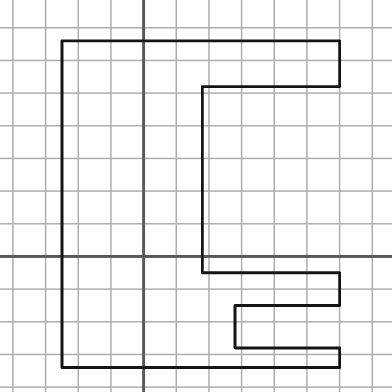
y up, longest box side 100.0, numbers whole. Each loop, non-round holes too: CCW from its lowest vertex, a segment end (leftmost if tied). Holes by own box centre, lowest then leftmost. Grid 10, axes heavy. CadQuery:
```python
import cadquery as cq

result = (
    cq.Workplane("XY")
    .moveTo(-25.0, -34.0)
    .lineTo(60.0, -34.0)
    .lineTo(60.0, -28.0)
    .lineTo(28.0, -28.0)
    .lineTo(28.0, -15.0)
    .lineTo(60.0, -15.0)
    .lineTo(60.0, -5.0)
    .lineTo(18.0, -5.0)
    .lineTo(18.0, 52.0)
    .lineTo(60.0, 52.0)
    .lineTo(60.0, 66.0)
    .lineTo(-25.0, 66.0)
    .close()
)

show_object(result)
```